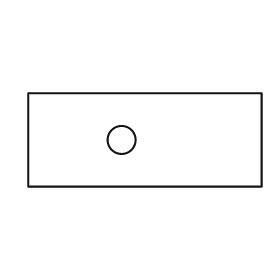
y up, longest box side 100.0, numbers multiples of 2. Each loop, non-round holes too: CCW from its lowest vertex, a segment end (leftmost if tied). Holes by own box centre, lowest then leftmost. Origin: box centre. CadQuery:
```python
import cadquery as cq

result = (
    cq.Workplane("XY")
    .moveTo(-50.0, -20.0)
    .lineTo(50.0, -20.0)
    .lineTo(50.0, 20.0)
    .lineTo(-50.0, 20.0)
    .close()
    .moveTo(-10.0, 0.0)
    .circle(6.0)
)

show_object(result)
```